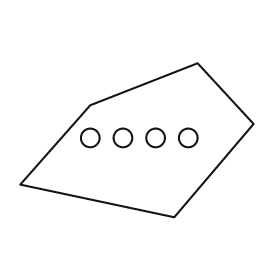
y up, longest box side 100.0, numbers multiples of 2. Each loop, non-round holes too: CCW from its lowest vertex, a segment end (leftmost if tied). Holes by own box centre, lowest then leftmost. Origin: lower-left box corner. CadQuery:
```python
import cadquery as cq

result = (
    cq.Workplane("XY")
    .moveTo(66.0, 0.0)
    .lineTo(100.0, 40.0)
    .lineTo(76.0, 66.0)
    .lineTo(30.0, 48.0)
    .lineTo(0.0, 14.0)
    .close()
    .moveTo(30.0, 34.0)
    .circle(4.0)
    .moveTo(44.0, 34.0)
    .circle(4.0)
    .moveTo(58.0, 34.0)
    .circle(4.0)
    .moveTo(72.0, 34.0)
    .circle(4.0)
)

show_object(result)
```